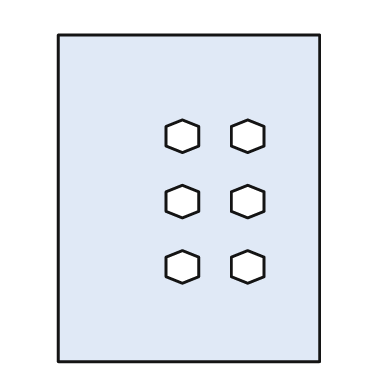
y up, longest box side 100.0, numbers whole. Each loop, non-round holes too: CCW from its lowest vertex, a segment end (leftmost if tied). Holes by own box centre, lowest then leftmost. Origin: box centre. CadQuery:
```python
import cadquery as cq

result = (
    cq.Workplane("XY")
    .moveTo(-40.0, -50.0)
    .lineTo(40.0, -50.0)
    .lineTo(40.0, 50.0)
    .lineTo(-40.0, 50.0)
    .close()
    .moveTo(-2.0, -26.0)
    .lineTo(3.0, -24.0)
    .lineTo(3.0, -18.0)
    .lineTo(-2.0, -16.0)
    .lineTo(-7.0, -18.0)
    .lineTo(-7.0, -24.0)
    .close()
    .moveTo(18.0, -26.0)
    .lineTo(23.0, -24.0)
    .lineTo(23.0, -18.0)
    .lineTo(18.0, -16.0)
    .lineTo(13.0, -18.0)
    .lineTo(13.0, -24.0)
    .close()
    .moveTo(-2.0, -6.0)
    .lineTo(3.0, -4.0)
    .lineTo(3.0, 2.0)
    .lineTo(-2.0, 4.0)
    .lineTo(-7.0, 2.0)
    .lineTo(-7.0, -4.0)
    .close()
    .moveTo(18.0, -6.0)
    .lineTo(23.0, -4.0)
    .lineTo(23.0, 2.0)
    .lineTo(18.0, 4.0)
    .lineTo(13.0, 2.0)
    .lineTo(13.0, -4.0)
    .close()
    .moveTo(-2.0, 14.0)
    .lineTo(3.0, 16.0)
    .lineTo(3.0, 22.0)
    .lineTo(-2.0, 24.0)
    .lineTo(-7.0, 22.0)
    .lineTo(-7.0, 16.0)
    .close()
    .moveTo(18.0, 14.0)
    .lineTo(23.0, 16.0)
    .lineTo(23.0, 22.0)
    .lineTo(18.0, 24.0)
    .lineTo(13.0, 22.0)
    .lineTo(13.0, 16.0)
    .close()
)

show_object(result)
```